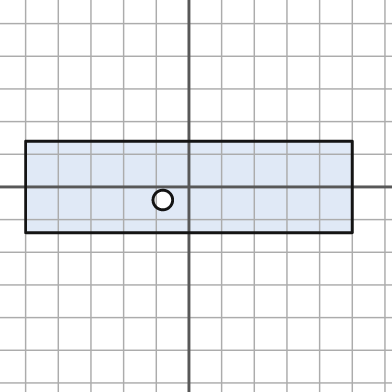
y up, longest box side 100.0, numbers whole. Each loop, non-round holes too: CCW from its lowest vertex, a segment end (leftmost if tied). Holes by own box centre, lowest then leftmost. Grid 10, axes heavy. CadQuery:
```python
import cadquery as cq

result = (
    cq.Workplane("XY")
    .moveTo(-50.0, -14.0)
    .lineTo(50.0, -14.0)
    .lineTo(50.0, 14.0)
    .lineTo(-50.0, 14.0)
    .close()
    .moveTo(-8.0, -4.0)
    .circle(3.0)
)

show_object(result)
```